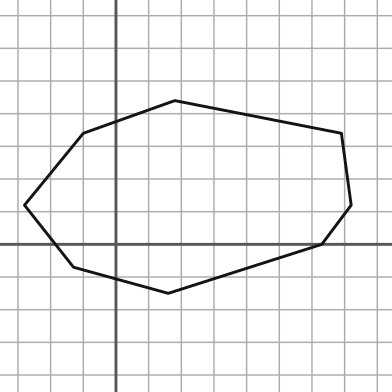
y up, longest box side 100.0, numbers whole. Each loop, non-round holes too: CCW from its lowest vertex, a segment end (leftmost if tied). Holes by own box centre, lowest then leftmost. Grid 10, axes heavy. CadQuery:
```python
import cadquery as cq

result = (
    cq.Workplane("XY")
    .moveTo(16.0, -15.0)
    .lineTo(63.0, 0.0)
    .lineTo(72.0, 12.0)
    .lineTo(69.0, 34.0)
    .lineTo(18.0, 44.0)
    .lineTo(-10.0, 34.0)
    .lineTo(-28.0, 12.0)
    .lineTo(-13.0, -7.0)
    .close()
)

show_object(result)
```